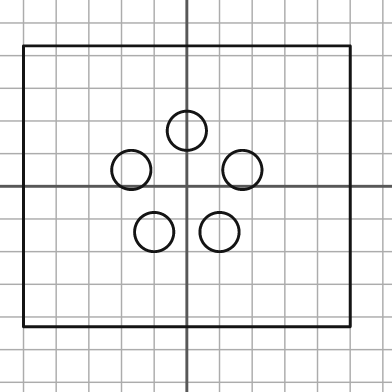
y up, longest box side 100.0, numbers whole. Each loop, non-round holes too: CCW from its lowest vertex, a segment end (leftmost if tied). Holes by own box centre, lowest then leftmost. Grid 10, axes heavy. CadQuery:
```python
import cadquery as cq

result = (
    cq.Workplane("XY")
    .moveTo(-50.0, -43.0)
    .lineTo(50.0, -43.0)
    .lineTo(50.0, 43.0)
    .lineTo(-50.0, 43.0)
    .close()
    .moveTo(-10.0, -14.0)
    .circle(6.0)
    .moveTo(10.0, -14.0)
    .circle(6.0)
    .moveTo(-17.0, 5.0)
    .circle(6.0)
    .moveTo(17.0, 5.0)
    .circle(6.0)
    .moveTo(0.0, 17.0)
    .circle(6.0)
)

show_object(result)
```